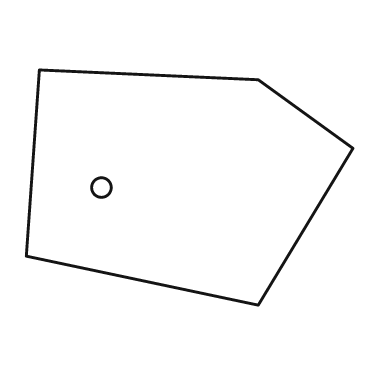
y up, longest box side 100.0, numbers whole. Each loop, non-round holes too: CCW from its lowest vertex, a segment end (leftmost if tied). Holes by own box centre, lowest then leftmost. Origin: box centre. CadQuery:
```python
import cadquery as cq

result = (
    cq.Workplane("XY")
    .moveTo(21.0, -36.0)
    .lineTo(50.0, 12.0)
    .lineTo(21.0, 33.0)
    .lineTo(-46.0, 36.0)
    .lineTo(-50.0, -21.0)
    .close()
    .moveTo(-27.0, 0.0)
    .circle(3.0)
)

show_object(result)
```